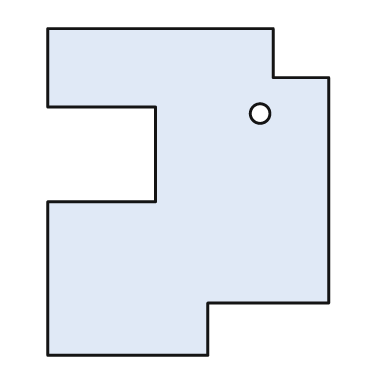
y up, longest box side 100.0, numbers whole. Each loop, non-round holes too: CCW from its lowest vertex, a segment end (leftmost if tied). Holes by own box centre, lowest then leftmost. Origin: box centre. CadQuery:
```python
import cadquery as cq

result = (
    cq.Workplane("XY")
    .moveTo(-43.0, -50.0)
    .lineTo(6.0, -50.0)
    .lineTo(6.0, -34.0)
    .lineTo(43.0, -34.0)
    .lineTo(43.0, 35.0)
    .lineTo(26.0, 35.0)
    .lineTo(26.0, 50.0)
    .lineTo(-43.0, 50.0)
    .lineTo(-43.0, 26.0)
    .lineTo(-10.0, 26.0)
    .lineTo(-10.0, -3.0)
    .lineTo(-43.0, -3.0)
    .close()
    .moveTo(22.0, 24.0)
    .circle(3.0)
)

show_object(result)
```